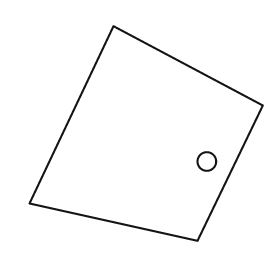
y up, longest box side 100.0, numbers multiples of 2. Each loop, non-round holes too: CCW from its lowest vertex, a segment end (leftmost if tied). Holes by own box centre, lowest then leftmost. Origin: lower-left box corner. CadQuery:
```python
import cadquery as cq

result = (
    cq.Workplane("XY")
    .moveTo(72.0, 0.0)
    .lineTo(100.0, 58.0)
    .lineTo(36.0, 92.0)
    .lineTo(0.0, 16.0)
    .close()
    .moveTo(76.0, 34.0)
    .circle(4.0)
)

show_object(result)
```